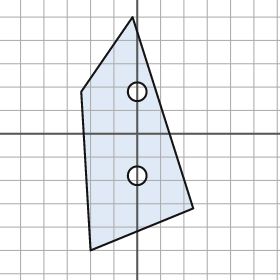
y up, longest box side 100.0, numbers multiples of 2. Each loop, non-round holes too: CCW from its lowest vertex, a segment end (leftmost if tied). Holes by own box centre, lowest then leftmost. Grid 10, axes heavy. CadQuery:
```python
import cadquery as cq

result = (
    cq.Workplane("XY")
    .moveTo(-20.0, -50.0)
    .lineTo(24.0, -32.0)
    .lineTo(-2.0, 50.0)
    .lineTo(-24.0, 18.0)
    .close()
    .moveTo(0.0, -18.0)
    .circle(4.0)
    .moveTo(0.0, 18.0)
    .circle(4.0)
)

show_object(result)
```